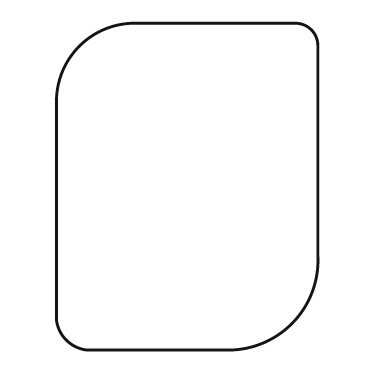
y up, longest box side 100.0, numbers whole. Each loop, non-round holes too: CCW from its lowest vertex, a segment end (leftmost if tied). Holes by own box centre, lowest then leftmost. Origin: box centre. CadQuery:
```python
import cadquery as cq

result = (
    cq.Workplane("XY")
    .moveTo(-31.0, -50.0)
    .lineTo(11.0, -50.0)
    .threePointArc((32.0, -42.0), (40.0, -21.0))
    .lineTo(40.0, 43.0)
    .threePointArc((38.0, 48.0), (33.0, 50.0))
    .lineTo(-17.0, 50.0)
    .threePointArc((-33.0, 43.0), (-40.0, 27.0))
    .lineTo(-40.0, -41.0)
    .threePointArc((-37.0, -47.0), (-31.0, -50.0))
    .close()
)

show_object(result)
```